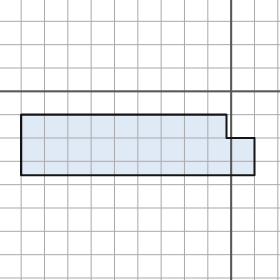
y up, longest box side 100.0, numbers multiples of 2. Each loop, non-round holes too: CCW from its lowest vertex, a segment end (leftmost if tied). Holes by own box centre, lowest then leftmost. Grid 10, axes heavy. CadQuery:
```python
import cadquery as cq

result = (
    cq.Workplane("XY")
    .moveTo(-90.0, -36.0)
    .lineTo(10.0, -36.0)
    .lineTo(10.0, -20.0)
    .lineTo(-2.0, -20.0)
    .lineTo(-2.0, -10.0)
    .lineTo(-90.0, -10.0)
    .close()
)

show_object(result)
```